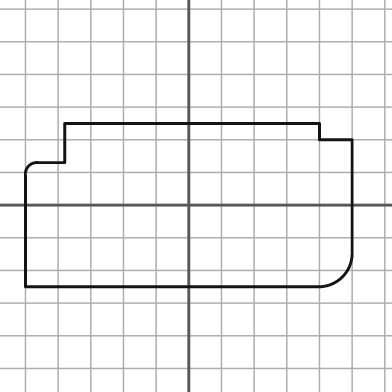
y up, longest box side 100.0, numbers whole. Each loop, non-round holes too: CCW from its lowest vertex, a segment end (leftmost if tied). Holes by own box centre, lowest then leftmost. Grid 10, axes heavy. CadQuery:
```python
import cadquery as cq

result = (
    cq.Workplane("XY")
    .moveTo(-50.0, -25.0)
    .lineTo(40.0, -25.0)
    .threePointArc((47.0, -22.0), (50.0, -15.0))
    .lineTo(50.0, 20.0)
    .lineTo(40.0, 20.0)
    .lineTo(40.0, 25.0)
    .lineTo(-38.0, 25.0)
    .lineTo(-38.0, 13.0)
    .lineTo(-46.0, 13.0)
    .threePointArc((-49.0, 12.0), (-50.0, 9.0))
    .close()
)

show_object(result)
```